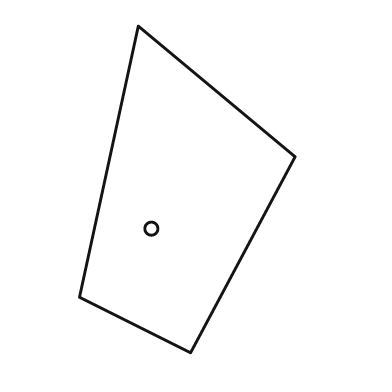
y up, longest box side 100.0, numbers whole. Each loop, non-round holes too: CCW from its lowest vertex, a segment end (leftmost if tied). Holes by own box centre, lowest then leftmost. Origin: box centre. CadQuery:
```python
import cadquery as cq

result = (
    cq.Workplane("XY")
    .moveTo(1.0, -50.0)
    .lineTo(33.0, 10.0)
    .lineTo(-15.0, 50.0)
    .lineTo(-33.0, -33.0)
    .close()
    .moveTo(-11.0, -12.0)
    .circle(2.0)
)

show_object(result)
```